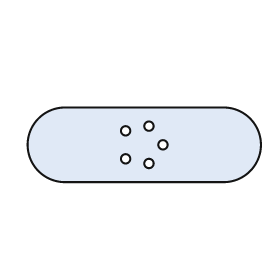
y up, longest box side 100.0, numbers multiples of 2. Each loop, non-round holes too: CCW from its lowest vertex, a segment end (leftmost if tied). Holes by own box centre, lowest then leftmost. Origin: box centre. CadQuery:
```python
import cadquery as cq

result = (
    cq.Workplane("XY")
    .moveTo(-34.0, -16.0)
    .lineTo(34.0, -16.0)
    .threePointArc((50.0, 0.0), (34.0, 16.0))
    .lineTo(-34.0, 16.0)
    .threePointArc((-50.0, 0.0), (-34.0, -16.0))
    .close()
    .moveTo(2.0, -8.0)
    .circle(2.0)
    .moveTo(-8.0, -6.0)
    .circle(2.0)
    .moveTo(8.0, 0.0)
    .circle(2.0)
    .moveTo(-8.0, 6.0)
    .circle(2.0)
    .moveTo(2.0, 8.0)
    .circle(2.0)
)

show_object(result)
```